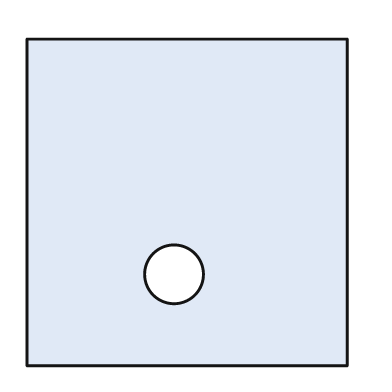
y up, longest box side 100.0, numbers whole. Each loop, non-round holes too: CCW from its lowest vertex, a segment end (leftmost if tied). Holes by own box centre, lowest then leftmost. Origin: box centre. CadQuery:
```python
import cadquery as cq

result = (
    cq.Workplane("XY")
    .moveTo(-49.0, -50.0)
    .lineTo(49.0, -50.0)
    .lineTo(49.0, 50.0)
    .lineTo(-49.0, 50.0)
    .close()
    .moveTo(-4.0, -22.0)
    .circle(9.0)
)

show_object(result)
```